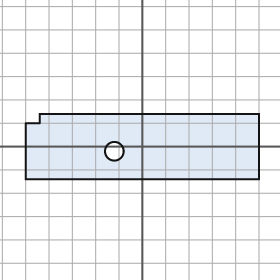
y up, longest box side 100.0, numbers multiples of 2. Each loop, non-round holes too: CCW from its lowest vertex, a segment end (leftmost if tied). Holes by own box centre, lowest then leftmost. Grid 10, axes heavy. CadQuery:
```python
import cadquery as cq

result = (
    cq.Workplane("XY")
    .moveTo(-50.0, -14.0)
    .lineTo(50.0, -14.0)
    .lineTo(50.0, 14.0)
    .lineTo(-44.0, 14.0)
    .lineTo(-44.0, 10.0)
    .lineTo(-50.0, 10.0)
    .close()
    .moveTo(-12.0, -2.0)
    .circle(4.0)
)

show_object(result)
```